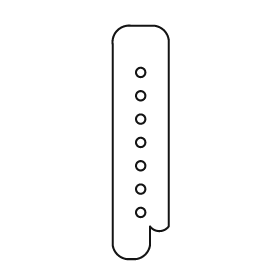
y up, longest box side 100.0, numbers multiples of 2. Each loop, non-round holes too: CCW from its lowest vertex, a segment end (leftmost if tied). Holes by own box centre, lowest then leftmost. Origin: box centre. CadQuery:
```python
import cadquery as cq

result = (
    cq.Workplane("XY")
    .moveTo(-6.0, -50.0)
    .lineTo(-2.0, -50.0)
    .threePointArc((2.0, -48.0), (4.0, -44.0))
    .lineTo(4.0, -36.0)
    .threePointArc((8.0, -38.0), (12.0, -36.0))
    .lineTo(12.0, 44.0)
    .threePointArc((10.0, 48.0), (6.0, 50.0))
    .lineTo(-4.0, 50.0)
    .threePointArc((-10.0, 48.0), (-12.0, 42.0))
    .lineTo(-12.0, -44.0)
    .threePointArc((-10.0, -48.0), (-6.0, -50.0))
    .close()
    .moveTo(0.0, -30.0)
    .circle(2.0)
    .moveTo(0.0, -20.0)
    .circle(2.0)
    .moveTo(0.0, -10.0)
    .circle(2.0)
    .moveTo(0.0, 0.0)
    .circle(2.0)
    .moveTo(0.0, 10.0)
    .circle(2.0)
    .moveTo(0.0, 20.0)
    .circle(2.0)
    .moveTo(0.0, 30.0)
    .circle(2.0)
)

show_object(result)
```